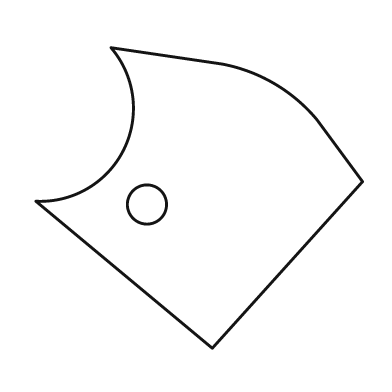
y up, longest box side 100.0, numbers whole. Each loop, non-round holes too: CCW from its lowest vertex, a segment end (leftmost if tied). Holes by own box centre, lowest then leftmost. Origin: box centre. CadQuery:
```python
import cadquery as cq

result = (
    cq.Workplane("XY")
    .moveTo(4.0, -46.0)
    .lineTo(50.0, 5.0)
    .lineTo(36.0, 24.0)
    .threePointArc((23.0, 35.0), (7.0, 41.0))
    .lineTo(-27.0, 46.0)
    .threePointArc((-23.0, 15.0), (-50.0, -1.0))
    .close()
    .moveTo(-16.0, -2.0)
    .circle(6.0)
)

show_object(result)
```